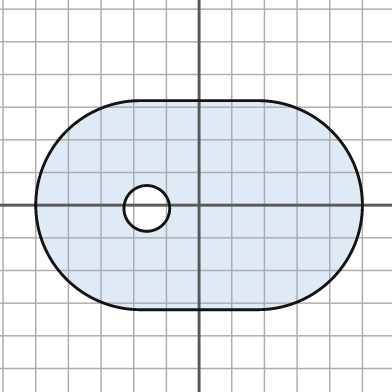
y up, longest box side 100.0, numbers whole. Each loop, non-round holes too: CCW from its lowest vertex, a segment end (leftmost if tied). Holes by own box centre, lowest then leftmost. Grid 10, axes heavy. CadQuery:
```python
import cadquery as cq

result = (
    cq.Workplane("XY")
    .moveTo(-18.0, -32.0)
    .lineTo(18.0, -32.0)
    .threePointArc((50.0, 0.0), (18.0, 32.0))
    .lineTo(-18.0, 32.0)
    .threePointArc((-50.0, 0.0), (-18.0, -32.0))
    .close()
    .moveTo(-16.0, -1.0)
    .circle(7.0)
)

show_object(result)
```